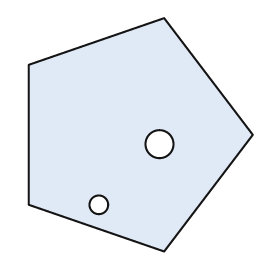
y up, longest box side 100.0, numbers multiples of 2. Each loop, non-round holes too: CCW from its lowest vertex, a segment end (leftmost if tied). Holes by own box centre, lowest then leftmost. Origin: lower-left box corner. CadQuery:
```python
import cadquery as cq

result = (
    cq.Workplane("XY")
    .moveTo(58.0, 0.0)
    .lineTo(96.0, 50.0)
    .lineTo(58.0, 100.0)
    .lineTo(0.0, 80.0)
    .lineTo(0.0, 20.0)
    .close()
    .moveTo(30.0, 20.0)
    .circle(4.0)
    .moveTo(56.0, 46.0)
    .circle(6.0)
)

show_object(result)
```